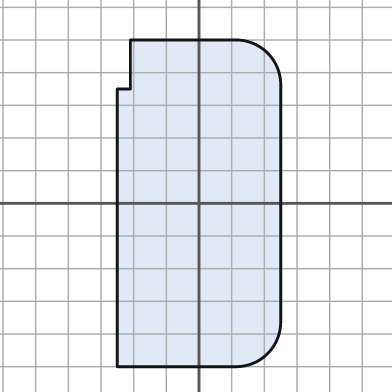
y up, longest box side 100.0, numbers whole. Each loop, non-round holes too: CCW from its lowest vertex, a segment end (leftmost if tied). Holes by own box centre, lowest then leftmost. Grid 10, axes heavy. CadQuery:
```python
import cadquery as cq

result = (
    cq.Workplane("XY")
    .moveTo(-25.0, -50.0)
    .lineTo(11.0, -50.0)
    .threePointArc((21.0, -46.0), (25.0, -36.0))
    .lineTo(25.0, 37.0)
    .threePointArc((21.0, 46.0), (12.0, 50.0))
    .lineTo(-21.0, 50.0)
    .lineTo(-21.0, 35.0)
    .lineTo(-25.0, 35.0)
    .close()
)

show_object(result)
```